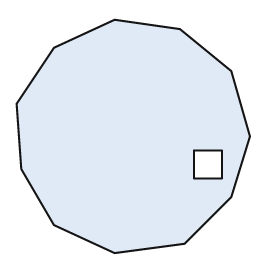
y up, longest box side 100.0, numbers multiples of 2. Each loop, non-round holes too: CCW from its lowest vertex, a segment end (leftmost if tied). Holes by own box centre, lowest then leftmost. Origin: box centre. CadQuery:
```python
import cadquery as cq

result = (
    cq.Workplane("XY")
    .moveTo(-8.0, -50.0)
    .lineTo(22.0, -46.0)
    .lineTo(42.0, -26.0)
    .lineTo(50.0, 0.0)
    .lineTo(42.0, 28.0)
    .lineTo(20.0, 46.0)
    .lineTo(-8.0, 50.0)
    .lineTo(-34.0, 38.0)
    .lineTo(-50.0, 14.0)
    .lineTo(-48.0, -14.0)
    .lineTo(-34.0, -38.0)
    .close()
    .moveTo(26.0, -18.0)
    .lineTo(38.0, -18.0)
    .lineTo(38.0, -6.0)
    .lineTo(26.0, -6.0)
    .close()
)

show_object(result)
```